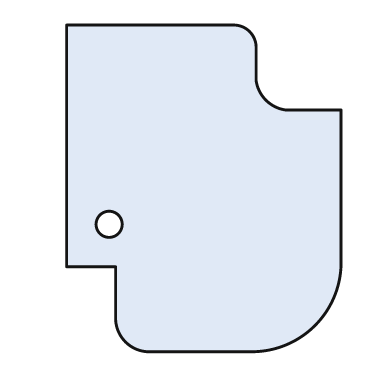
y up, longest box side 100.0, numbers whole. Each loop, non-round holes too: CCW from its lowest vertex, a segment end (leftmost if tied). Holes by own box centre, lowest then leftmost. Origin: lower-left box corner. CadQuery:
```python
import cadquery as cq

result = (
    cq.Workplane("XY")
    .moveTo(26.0, 0.0)
    .lineTo(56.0, 0.0)
    .threePointArc((76.0, 8.0), (84.0, 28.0))
    .lineTo(84.0, 74.0)
    .lineTo(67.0, 74.0)
    .threePointArc((61.0, 77.0), (58.0, 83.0))
    .lineTo(58.0, 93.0)
    .threePointArc((56.0, 98.0), (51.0, 100.0))
    .lineTo(0.0, 100.0)
    .lineTo(0.0, 26.0)
    .lineTo(15.0, 26.0)
    .lineTo(15.0, 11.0)
    .threePointArc((18.0, 3.0), (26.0, 0.0))
    .close()
    .moveTo(13.0, 39.0)
    .circle(4.0)
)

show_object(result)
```